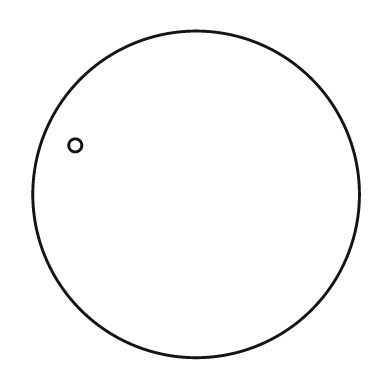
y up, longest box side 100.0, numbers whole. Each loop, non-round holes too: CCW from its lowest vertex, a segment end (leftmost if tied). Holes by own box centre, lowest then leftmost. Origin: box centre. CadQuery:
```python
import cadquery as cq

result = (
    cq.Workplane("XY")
    .moveTo(0.0, 0.0)
    .circle(50.0)
    .moveTo(-37.0, 15.0)
    .circle(2.0)
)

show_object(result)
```